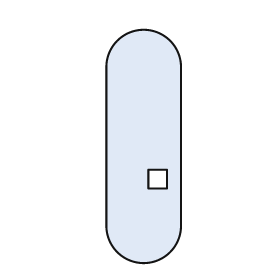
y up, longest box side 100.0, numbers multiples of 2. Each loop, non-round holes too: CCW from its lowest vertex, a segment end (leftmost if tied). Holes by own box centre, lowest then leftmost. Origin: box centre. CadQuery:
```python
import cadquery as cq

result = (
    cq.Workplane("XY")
    .moveTo(-16.0, -34.0)
    .threePointArc((0.0, -50.0), (16.0, -34.0))
    .lineTo(16.0, 34.0)
    .threePointArc((0.0, 50.0), (-16.0, 34.0))
    .close()
    .moveTo(2.0, -18.0)
    .lineTo(10.0, -18.0)
    .lineTo(10.0, -10.0)
    .lineTo(2.0, -10.0)
    .close()
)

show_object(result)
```